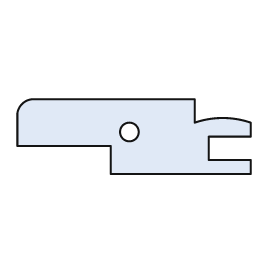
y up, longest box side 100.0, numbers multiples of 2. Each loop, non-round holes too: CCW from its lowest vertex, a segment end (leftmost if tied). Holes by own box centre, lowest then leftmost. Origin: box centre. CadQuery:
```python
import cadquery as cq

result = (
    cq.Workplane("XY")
    .moveTo(-10.0, -16.0)
    .lineTo(50.0, -16.0)
    .lineTo(50.0, -10.0)
    .lineTo(32.0, -10.0)
    .lineTo(32.0, 0.0)
    .lineTo(50.0, 0.0)
    .lineTo(50.0, 6.0)
    .threePointArc((38.0, 8.0), (26.0, 6.0))
    .lineTo(26.0, 16.0)
    .lineTo(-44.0, 16.0)
    .threePointArc((-48.0, 14.0), (-50.0, 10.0))
    .lineTo(-50.0, -4.0)
    .lineTo(-10.0, -4.0)
    .close()
    .moveTo(-2.0, 2.0)
    .circle(4.0)
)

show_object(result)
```